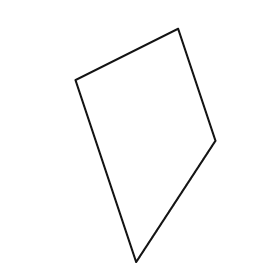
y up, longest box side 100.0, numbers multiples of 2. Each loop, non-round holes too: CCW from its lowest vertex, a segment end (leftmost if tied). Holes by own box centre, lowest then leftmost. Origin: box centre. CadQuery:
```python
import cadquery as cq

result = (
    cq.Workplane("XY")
    .moveTo(-4.0, -50.0)
    .lineTo(30.0, 2.0)
    .lineTo(14.0, 50.0)
    .lineTo(-30.0, 28.0)
    .close()
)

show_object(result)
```